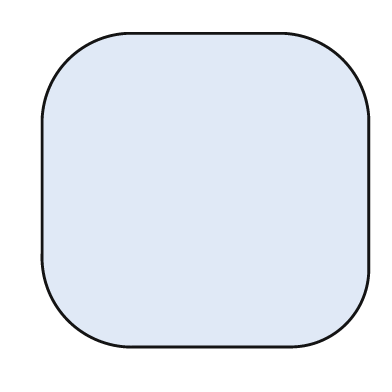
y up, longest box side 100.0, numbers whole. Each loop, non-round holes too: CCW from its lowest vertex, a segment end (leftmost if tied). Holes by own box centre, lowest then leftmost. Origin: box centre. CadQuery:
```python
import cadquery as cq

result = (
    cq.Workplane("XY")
    .moveTo(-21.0, -48.0)
    .lineTo(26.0, -48.0)
    .threePointArc((43.0, -41.0), (50.0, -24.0))
    .lineTo(50.0, 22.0)
    .threePointArc((42.0, 40.0), (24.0, 48.0))
    .lineTo(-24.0, 48.0)
    .threePointArc((-42.0, 40.0), (-50.0, 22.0))
    .lineTo(-50.0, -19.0)
    .threePointArc((-42.0, -40.0), (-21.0, -48.0))
    .close()
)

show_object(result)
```